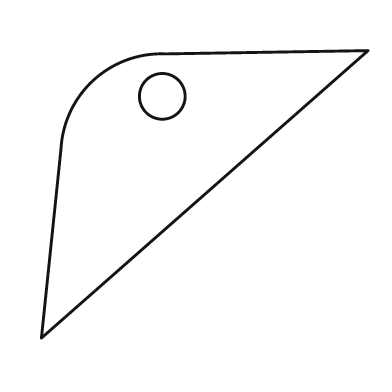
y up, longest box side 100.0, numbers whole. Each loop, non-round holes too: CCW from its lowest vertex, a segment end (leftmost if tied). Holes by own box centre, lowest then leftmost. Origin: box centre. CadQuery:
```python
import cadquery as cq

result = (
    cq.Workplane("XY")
    .moveTo(-50.0, -44.0)
    .lineTo(50.0, 44.0)
    .lineTo(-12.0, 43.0)
    .threePointArc((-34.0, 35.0), (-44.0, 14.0))
    .close()
    .moveTo(-13.0, 30.0)
    .circle(7.0)
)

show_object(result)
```